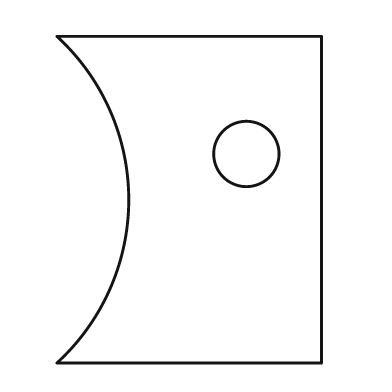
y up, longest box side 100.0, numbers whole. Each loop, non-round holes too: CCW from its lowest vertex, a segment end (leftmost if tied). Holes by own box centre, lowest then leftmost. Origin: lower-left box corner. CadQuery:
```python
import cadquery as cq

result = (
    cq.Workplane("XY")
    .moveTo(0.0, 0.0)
    .lineTo(81.0, 0.0)
    .lineTo(81.0, 100.0)
    .lineTo(0.0, 100.0)
    .threePointArc((22.0, 50.0), (0.0, 0.0))
    .close()
    .moveTo(58.0, 64.0)
    .circle(10.0)
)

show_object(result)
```